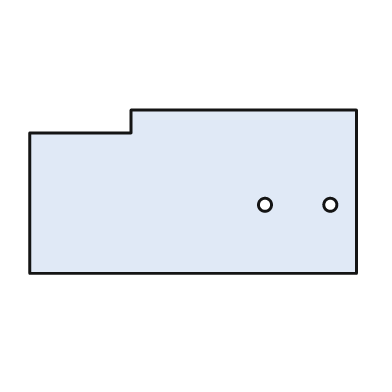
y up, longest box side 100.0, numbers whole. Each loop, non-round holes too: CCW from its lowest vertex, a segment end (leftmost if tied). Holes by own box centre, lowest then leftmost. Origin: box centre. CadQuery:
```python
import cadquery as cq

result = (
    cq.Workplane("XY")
    .moveTo(-50.0, -25.0)
    .lineTo(50.0, -25.0)
    .lineTo(50.0, 25.0)
    .lineTo(-19.0, 25.0)
    .lineTo(-19.0, 18.0)
    .lineTo(-50.0, 18.0)
    .close()
    .moveTo(22.0, -4.0)
    .circle(2.0)
    .moveTo(42.0, -4.0)
    .circle(2.0)
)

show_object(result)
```